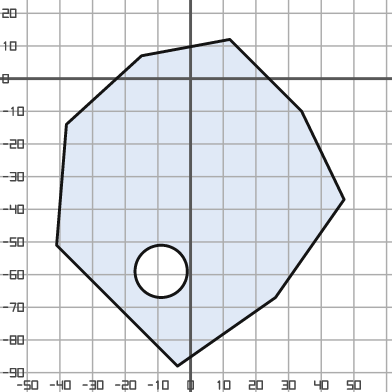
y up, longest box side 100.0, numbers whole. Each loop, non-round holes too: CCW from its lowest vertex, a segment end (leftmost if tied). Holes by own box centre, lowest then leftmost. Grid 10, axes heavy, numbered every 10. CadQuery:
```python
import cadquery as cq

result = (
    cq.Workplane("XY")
    .moveTo(-4.0, -88.0)
    .lineTo(26.0, -67.0)
    .lineTo(47.0, -37.0)
    .lineTo(34.0, -10.0)
    .lineTo(12.0, 12.0)
    .lineTo(-15.0, 7.0)
    .lineTo(-38.0, -14.0)
    .lineTo(-41.0, -51.0)
    .close()
    .moveTo(-9.0, -59.0)
    .circle(8.0)
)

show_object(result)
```